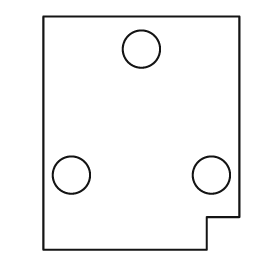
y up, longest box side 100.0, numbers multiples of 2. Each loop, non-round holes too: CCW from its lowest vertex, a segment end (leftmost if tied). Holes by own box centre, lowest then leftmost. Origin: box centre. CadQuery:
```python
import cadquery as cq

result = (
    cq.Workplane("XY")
    .moveTo(-42.0, -50.0)
    .lineTo(28.0, -50.0)
    .lineTo(28.0, -36.0)
    .lineTo(42.0, -36.0)
    .lineTo(42.0, 50.0)
    .lineTo(-42.0, 50.0)
    .close()
    .moveTo(-30.0, -18.0)
    .circle(8.0)
    .moveTo(30.0, -18.0)
    .circle(8.0)
    .moveTo(0.0, 36.0)
    .circle(8.0)
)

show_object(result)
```